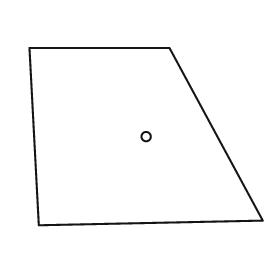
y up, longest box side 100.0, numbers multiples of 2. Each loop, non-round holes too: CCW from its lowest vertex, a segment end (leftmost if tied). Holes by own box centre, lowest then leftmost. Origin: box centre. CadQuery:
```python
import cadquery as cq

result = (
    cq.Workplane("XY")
    .moveTo(-46.0, -38.0)
    .lineTo(50.0, -36.0)
    .lineTo(10.0, 38.0)
    .lineTo(-50.0, 38.0)
    .close()
    .moveTo(0.0, 0.0)
    .circle(2.0)
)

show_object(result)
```